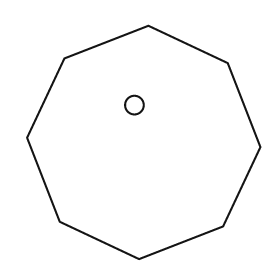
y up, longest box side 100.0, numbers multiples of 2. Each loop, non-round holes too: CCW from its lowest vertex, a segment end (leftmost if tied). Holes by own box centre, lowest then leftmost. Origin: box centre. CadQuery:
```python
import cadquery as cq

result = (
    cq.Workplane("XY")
    .moveTo(-2.0, -50.0)
    .lineTo(34.0, -36.0)
    .lineTo(50.0, -2.0)
    .lineTo(36.0, 34.0)
    .lineTo(2.0, 50.0)
    .lineTo(-34.0, 36.0)
    .lineTo(-50.0, 2.0)
    .lineTo(-36.0, -34.0)
    .close()
    .moveTo(-4.0, 16.0)
    .circle(4.0)
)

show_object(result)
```